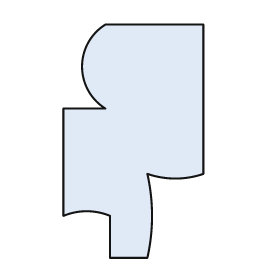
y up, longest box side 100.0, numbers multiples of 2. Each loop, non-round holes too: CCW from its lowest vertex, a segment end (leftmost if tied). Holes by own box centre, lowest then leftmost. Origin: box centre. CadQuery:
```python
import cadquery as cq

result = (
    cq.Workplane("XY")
    .moveTo(-10.0, -50.0)
    .lineTo(6.0, -50.0)
    .threePointArc((8.0, -32.0), (6.0, -14.0))
    .threePointArc((18.0, -16.0), (30.0, -14.0))
    .lineTo(30.0, 50.0)
    .lineTo(-12.0, 50.0)
    .threePointArc((-22.0, 32.0), (-12.0, 14.0))
    .lineTo(-30.0, 14.0)
    .lineTo(-30.0, -32.0)
    .threePointArc((-20.0, -30.0), (-10.0, -32.0))
    .close()
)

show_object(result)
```